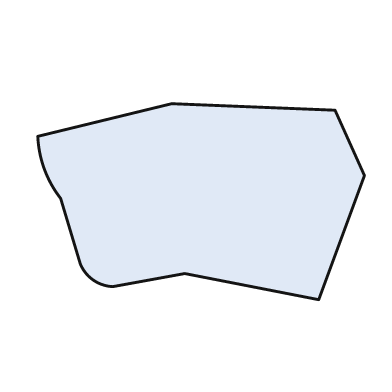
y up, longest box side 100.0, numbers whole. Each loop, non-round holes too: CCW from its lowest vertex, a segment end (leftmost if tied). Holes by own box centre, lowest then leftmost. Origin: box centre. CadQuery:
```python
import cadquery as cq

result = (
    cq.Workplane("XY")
    .moveTo(36.0, -30.0)
    .lineTo(50.0, 8.0)
    .lineTo(41.0, 28.0)
    .lineTo(-9.0, 30.0)
    .lineTo(-50.0, 20.0)
    .threePointArc((-48.0, 10.0), (-43.0, 1.0))
    .lineTo(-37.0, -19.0)
    .threePointArc((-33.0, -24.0), (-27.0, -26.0))
    .lineTo(-5.0, -22.0)
    .close()
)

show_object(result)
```